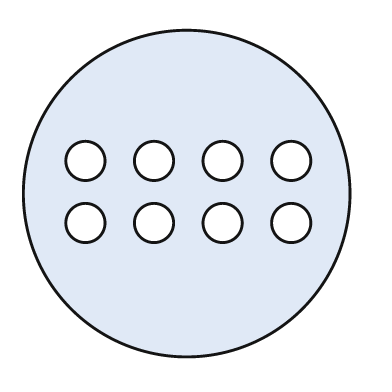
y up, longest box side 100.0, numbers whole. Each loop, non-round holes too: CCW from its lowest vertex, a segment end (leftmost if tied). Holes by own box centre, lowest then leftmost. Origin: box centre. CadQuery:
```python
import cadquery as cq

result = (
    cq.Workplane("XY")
    .moveTo(0.0, 0.0)
    .circle(50.0)
    .moveTo(-31.0, -9.0)
    .circle(6.0)
    .moveTo(-10.0, -9.0)
    .circle(6.0)
    .moveTo(11.0, -9.0)
    .circle(6.0)
    .moveTo(32.0, -9.0)
    .circle(6.0)
    .moveTo(-31.0, 10.0)
    .circle(6.0)
    .moveTo(-10.0, 10.0)
    .circle(6.0)
    .moveTo(11.0, 10.0)
    .circle(6.0)
    .moveTo(32.0, 10.0)
    .circle(6.0)
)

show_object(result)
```